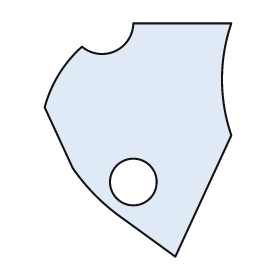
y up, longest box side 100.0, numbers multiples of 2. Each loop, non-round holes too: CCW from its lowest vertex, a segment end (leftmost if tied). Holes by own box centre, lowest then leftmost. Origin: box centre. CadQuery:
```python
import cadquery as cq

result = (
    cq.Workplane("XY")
    .moveTo(16.0, -50.0)
    .lineTo(40.0, 2.0)
    .threePointArc((36.0, 26.0), (40.0, 50.0))
    .lineTo(-2.0, 50.0)
    .threePointArc((-10.0, 38.0), (-24.0, 40.0))
    .threePointArc((-34.0, 28.0), (-40.0, 14.0))
    .lineTo(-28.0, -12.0)
    .threePointArc((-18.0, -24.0), (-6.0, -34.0))
    .close()
    .moveTo(-2.0, -18.0)
    .circle(10.0)
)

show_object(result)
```